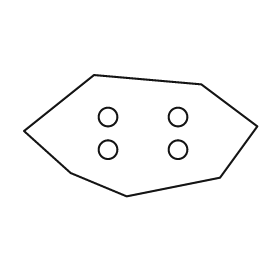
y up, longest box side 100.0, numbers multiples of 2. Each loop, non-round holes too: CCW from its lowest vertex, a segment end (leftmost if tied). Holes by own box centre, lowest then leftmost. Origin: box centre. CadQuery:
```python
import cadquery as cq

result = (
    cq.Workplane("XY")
    .moveTo(-6.0, -26.0)
    .lineTo(34.0, -18.0)
    .lineTo(50.0, 4.0)
    .lineTo(26.0, 22.0)
    .lineTo(-20.0, 26.0)
    .lineTo(-50.0, 2.0)
    .lineTo(-30.0, -16.0)
    .close()
    .moveTo(-14.0, -6.0)
    .circle(4.0)
    .moveTo(16.0, -6.0)
    .circle(4.0)
    .moveTo(-14.0, 8.0)
    .circle(4.0)
    .moveTo(16.0, 8.0)
    .circle(4.0)
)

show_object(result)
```